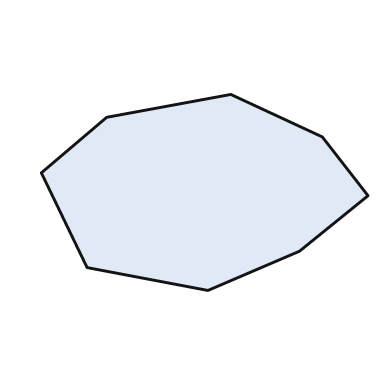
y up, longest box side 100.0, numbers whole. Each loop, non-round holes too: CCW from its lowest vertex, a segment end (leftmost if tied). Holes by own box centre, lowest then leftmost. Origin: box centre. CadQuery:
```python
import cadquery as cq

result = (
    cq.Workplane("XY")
    .moveTo(1.0, -30.0)
    .lineTo(29.0, -18.0)
    .lineTo(50.0, -1.0)
    .lineTo(36.0, 17.0)
    .lineTo(8.0, 30.0)
    .lineTo(-30.0, 23.0)
    .lineTo(-50.0, 6.0)
    .lineTo(-36.0, -23.0)
    .close()
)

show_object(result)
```